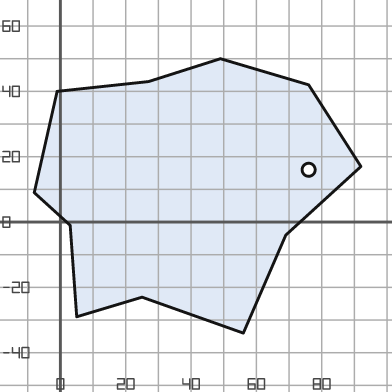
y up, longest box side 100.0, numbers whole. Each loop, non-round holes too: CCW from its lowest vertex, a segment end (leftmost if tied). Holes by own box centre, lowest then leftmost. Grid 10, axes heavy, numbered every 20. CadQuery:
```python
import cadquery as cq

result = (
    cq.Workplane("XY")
    .moveTo(56.0, -34.0)
    .lineTo(69.0, -4.0)
    .lineTo(92.0, 17.0)
    .lineTo(76.0, 42.0)
    .lineTo(49.0, 50.0)
    .lineTo(27.0, 43.0)
    .lineTo(-1.0, 40.0)
    .lineTo(-8.0, 9.0)
    .lineTo(3.0, -1.0)
    .lineTo(5.0, -29.0)
    .lineTo(25.0, -23.0)
    .close()
    .moveTo(76.0, 16.0)
    .circle(2.0)
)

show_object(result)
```